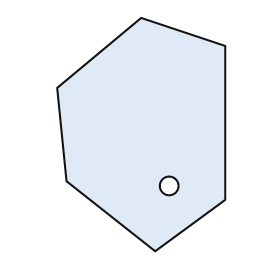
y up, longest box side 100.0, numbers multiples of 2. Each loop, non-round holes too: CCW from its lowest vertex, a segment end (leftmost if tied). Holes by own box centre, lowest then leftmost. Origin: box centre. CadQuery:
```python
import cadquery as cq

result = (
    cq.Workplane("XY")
    .moveTo(6.0, -50.0)
    .lineTo(36.0, -28.0)
    .lineTo(36.0, 38.0)
    .lineTo(0.0, 50.0)
    .lineTo(-36.0, 20.0)
    .lineTo(-32.0, -20.0)
    .close()
    .moveTo(12.0, -22.0)
    .circle(4.0)
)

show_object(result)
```